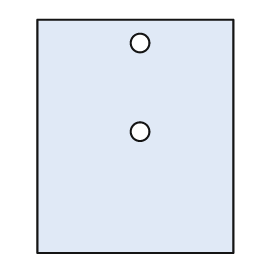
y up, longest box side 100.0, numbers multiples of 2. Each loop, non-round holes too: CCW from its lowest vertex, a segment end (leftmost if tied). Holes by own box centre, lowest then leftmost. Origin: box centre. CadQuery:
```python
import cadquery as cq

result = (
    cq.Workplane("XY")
    .moveTo(-42.0, -50.0)
    .lineTo(42.0, -50.0)
    .lineTo(42.0, 50.0)
    .lineTo(-42.0, 50.0)
    .close()
    .moveTo(2.0, 2.0)
    .circle(4.0)
    .moveTo(2.0, 40.0)
    .circle(4.0)
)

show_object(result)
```